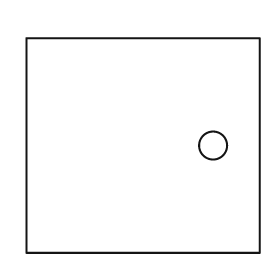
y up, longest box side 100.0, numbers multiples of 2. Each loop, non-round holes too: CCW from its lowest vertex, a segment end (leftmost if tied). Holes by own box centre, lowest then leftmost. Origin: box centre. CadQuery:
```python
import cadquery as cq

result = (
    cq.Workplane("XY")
    .moveTo(-50.0, -46.0)
    .lineTo(50.0, -46.0)
    .lineTo(50.0, 46.0)
    .lineTo(-50.0, 46.0)
    .close()
    .moveTo(30.0, 0.0)
    .circle(6.0)
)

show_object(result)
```